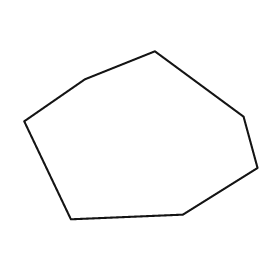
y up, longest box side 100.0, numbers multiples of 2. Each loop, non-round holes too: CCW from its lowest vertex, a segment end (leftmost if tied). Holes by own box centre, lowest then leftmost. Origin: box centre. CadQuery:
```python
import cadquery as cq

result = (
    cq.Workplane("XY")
    .moveTo(-30.0, -36.0)
    .lineTo(18.0, -34.0)
    .lineTo(50.0, -14.0)
    .lineTo(44.0, 8.0)
    .lineTo(6.0, 36.0)
    .lineTo(-24.0, 24.0)
    .lineTo(-50.0, 6.0)
    .close()
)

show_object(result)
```